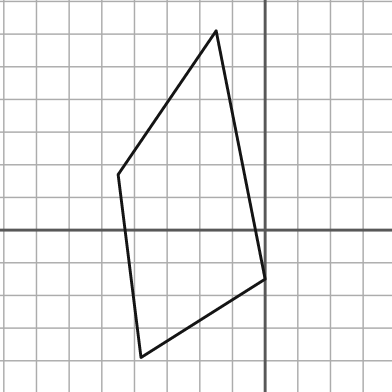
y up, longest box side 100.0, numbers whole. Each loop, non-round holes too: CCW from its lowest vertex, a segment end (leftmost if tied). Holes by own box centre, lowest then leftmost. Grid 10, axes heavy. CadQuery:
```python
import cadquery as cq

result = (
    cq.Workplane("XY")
    .moveTo(-38.0, -39.0)
    .lineTo(0.0, -15.0)
    .lineTo(-15.0, 61.0)
    .lineTo(-45.0, 17.0)
    .close()
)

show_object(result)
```